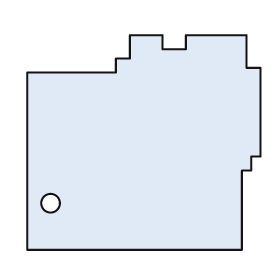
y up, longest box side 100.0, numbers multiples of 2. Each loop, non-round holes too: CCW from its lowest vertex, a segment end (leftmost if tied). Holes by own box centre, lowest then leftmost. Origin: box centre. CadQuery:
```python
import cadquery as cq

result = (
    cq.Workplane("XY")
    .moveTo(-50.0, -46.0)
    .lineTo(42.0, -46.0)
    .lineTo(42.0, -12.0)
    .lineTo(46.0, -12.0)
    .lineTo(46.0, -6.0)
    .lineTo(50.0, -6.0)
    .lineTo(50.0, 32.0)
    .lineTo(44.0, 32.0)
    .lineTo(44.0, 46.0)
    .lineTo(18.0, 46.0)
    .lineTo(18.0, 40.0)
    .lineTo(8.0, 40.0)
    .lineTo(8.0, 46.0)
    .lineTo(-6.0, 46.0)
    .lineTo(-6.0, 36.0)
    .lineTo(-12.0, 36.0)
    .lineTo(-12.0, 30.0)
    .lineTo(-50.0, 30.0)
    .close()
    .moveTo(-40.0, -26.0)
    .circle(4.0)
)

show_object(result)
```